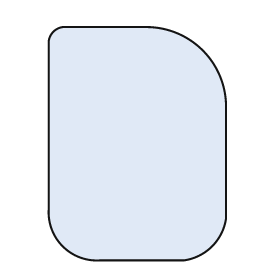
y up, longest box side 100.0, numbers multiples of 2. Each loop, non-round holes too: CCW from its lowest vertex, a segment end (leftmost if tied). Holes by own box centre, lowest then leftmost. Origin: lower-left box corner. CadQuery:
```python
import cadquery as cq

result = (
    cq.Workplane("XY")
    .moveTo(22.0, 0.0)
    .lineTo(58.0, 0.0)
    .threePointArc((70.0, 6.0), (76.0, 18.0))
    .lineTo(76.0, 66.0)
    .threePointArc((66.0, 90.0), (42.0, 100.0))
    .lineTo(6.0, 100.0)
    .threePointArc((2.0, 98.0), (0.0, 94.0))
    .lineTo(0.0, 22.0)
    .threePointArc((6.0, 6.0), (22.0, 0.0))
    .close()
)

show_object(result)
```